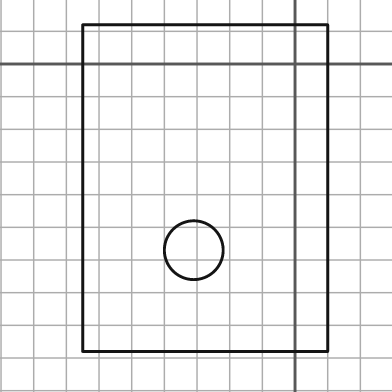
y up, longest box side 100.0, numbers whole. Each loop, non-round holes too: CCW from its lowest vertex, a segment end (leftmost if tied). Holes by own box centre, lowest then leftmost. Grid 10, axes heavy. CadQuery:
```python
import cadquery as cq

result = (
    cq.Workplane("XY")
    .moveTo(-65.0, -88.0)
    .lineTo(10.0, -88.0)
    .lineTo(10.0, 12.0)
    .lineTo(-65.0, 12.0)
    .close()
    .moveTo(-31.0, -57.0)
    .circle(9.0)
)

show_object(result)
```